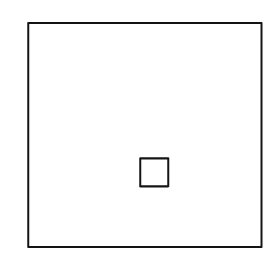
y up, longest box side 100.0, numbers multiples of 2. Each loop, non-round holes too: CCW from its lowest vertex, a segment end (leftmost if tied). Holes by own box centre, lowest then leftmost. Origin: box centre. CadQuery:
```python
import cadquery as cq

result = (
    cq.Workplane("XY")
    .moveTo(-50.0, -48.0)
    .lineTo(50.0, -48.0)
    .lineTo(50.0, 48.0)
    .lineTo(-50.0, 48.0)
    .close()
    .moveTo(-2.0, -22.0)
    .lineTo(10.0, -22.0)
    .lineTo(10.0, -10.0)
    .lineTo(-2.0, -10.0)
    .close()
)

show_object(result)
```